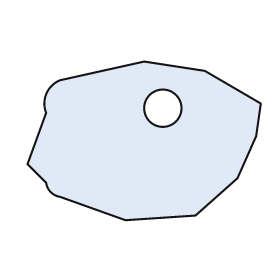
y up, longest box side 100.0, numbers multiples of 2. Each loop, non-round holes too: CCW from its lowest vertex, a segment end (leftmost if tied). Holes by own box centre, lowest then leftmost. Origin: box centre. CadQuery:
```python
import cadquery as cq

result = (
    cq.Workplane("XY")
    .moveTo(-8.0, -34.0)
    .lineTo(22.0, -32.0)
    .lineTo(40.0, -16.0)
    .lineTo(48.0, 2.0)
    .lineTo(50.0, 16.0)
    .lineTo(26.0, 30.0)
    .lineTo(0.0, 34.0)
    .lineTo(-36.0, 26.0)
    .threePointArc((-42.0, 20.0), (-42.0, 12.0))
    .lineTo(-50.0, -10.0)
    .lineTo(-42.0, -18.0)
    .threePointArc((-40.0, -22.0), (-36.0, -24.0))
    .close()
    .moveTo(8.0, 14.0)
    .circle(8.0)
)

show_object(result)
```